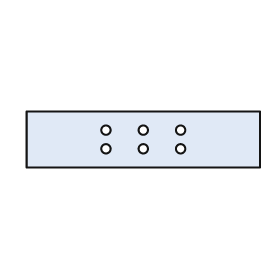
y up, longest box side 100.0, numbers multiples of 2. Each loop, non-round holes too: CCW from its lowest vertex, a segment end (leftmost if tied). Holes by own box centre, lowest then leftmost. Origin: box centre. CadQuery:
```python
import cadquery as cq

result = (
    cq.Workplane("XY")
    .moveTo(-50.0, -12.0)
    .lineTo(50.0, -12.0)
    .lineTo(50.0, 12.0)
    .lineTo(-50.0, 12.0)
    .close()
    .moveTo(-16.0, -4.0)
    .circle(2.0)
    .moveTo(0.0, -4.0)
    .circle(2.0)
    .moveTo(16.0, -4.0)
    .circle(2.0)
    .moveTo(-16.0, 4.0)
    .circle(2.0)
    .moveTo(0.0, 4.0)
    .circle(2.0)
    .moveTo(16.0, 4.0)
    .circle(2.0)
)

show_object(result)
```